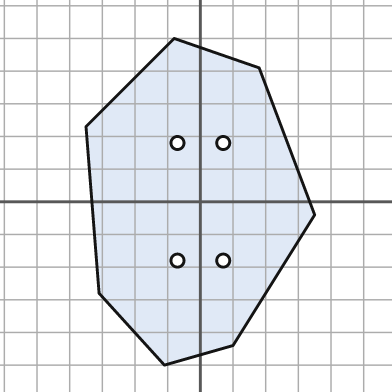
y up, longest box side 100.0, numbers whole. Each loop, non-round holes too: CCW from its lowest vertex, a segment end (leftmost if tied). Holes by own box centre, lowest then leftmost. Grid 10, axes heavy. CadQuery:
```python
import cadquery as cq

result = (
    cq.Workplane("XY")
    .moveTo(-11.0, -50.0)
    .lineTo(10.0, -44.0)
    .lineTo(35.0, -4.0)
    .lineTo(18.0, 41.0)
    .lineTo(-8.0, 50.0)
    .lineTo(-35.0, 23.0)
    .lineTo(-31.0, -28.0)
    .close()
    .moveTo(-7.0, -18.0)
    .circle(2.0)
    .moveTo(7.0, -18.0)
    .circle(2.0)
    .moveTo(-7.0, 18.0)
    .circle(2.0)
    .moveTo(7.0, 18.0)
    .circle(2.0)
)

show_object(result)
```